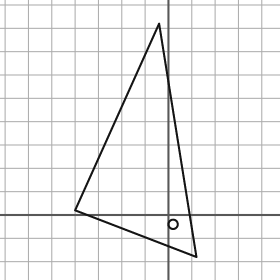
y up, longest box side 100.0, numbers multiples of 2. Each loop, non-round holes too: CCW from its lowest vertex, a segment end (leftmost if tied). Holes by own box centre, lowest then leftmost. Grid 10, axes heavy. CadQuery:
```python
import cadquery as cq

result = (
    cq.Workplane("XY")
    .moveTo(12.0, -18.0)
    .lineTo(-4.0, 82.0)
    .lineTo(-40.0, 2.0)
    .close()
    .moveTo(2.0, -4.0)
    .circle(2.0)
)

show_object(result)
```